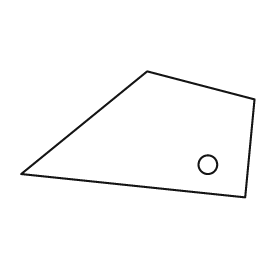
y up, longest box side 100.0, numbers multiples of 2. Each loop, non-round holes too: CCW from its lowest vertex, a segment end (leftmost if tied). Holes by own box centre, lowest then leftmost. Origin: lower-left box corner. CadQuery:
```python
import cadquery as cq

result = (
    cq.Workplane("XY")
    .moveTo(96.0, 0.0)
    .lineTo(100.0, 42.0)
    .lineTo(54.0, 54.0)
    .lineTo(0.0, 10.0)
    .close()
    .moveTo(80.0, 14.0)
    .circle(4.0)
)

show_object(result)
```